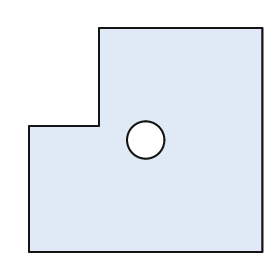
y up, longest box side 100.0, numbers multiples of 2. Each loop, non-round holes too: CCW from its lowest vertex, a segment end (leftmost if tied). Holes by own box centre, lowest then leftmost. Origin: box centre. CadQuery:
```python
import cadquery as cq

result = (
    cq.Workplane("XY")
    .moveTo(-50.0, -48.0)
    .lineTo(50.0, -48.0)
    .lineTo(50.0, 48.0)
    .lineTo(-20.0, 48.0)
    .lineTo(-20.0, 6.0)
    .lineTo(-50.0, 6.0)
    .close()
    .moveTo(0.0, 0.0)
    .circle(8.0)
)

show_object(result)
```